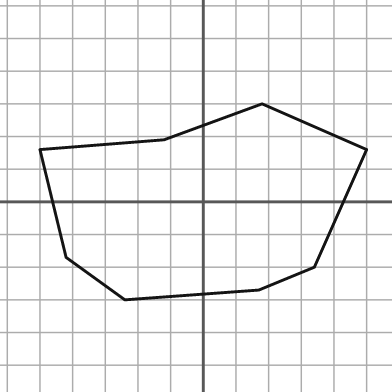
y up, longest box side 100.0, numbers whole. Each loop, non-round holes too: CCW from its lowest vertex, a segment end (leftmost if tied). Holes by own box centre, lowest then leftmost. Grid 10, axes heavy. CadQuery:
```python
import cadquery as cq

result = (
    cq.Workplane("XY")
    .moveTo(-24.0, -30.0)
    .lineTo(17.0, -27.0)
    .lineTo(34.0, -20.0)
    .lineTo(50.0, 16.0)
    .lineTo(18.0, 30.0)
    .lineTo(-12.0, 19.0)
    .lineTo(-50.0, 16.0)
    .lineTo(-42.0, -17.0)
    .close()
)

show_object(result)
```